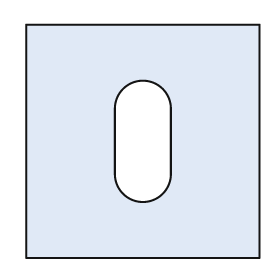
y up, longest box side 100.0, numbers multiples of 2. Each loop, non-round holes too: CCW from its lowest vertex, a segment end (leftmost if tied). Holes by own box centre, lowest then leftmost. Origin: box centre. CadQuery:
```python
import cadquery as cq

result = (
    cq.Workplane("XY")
    .moveTo(-50.0, -50.0)
    .lineTo(50.0, -50.0)
    .lineTo(50.0, 50.0)
    .lineTo(-50.0, 50.0)
    .close()
    .moveTo(-12.0, -14.0)
    .threePointArc((0.0, -26.0), (12.0, -14.0))
    .lineTo(12.0, 14.0)
    .threePointArc((0.0, 26.0), (-12.0, 14.0))
    .close()
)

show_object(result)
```